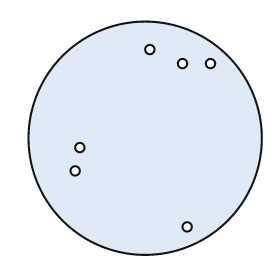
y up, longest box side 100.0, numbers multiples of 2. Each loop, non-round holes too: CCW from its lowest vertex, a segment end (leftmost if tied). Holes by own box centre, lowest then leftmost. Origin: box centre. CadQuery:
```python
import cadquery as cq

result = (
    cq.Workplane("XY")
    .moveTo(0.0, 0.0)
    .circle(50.0)
    .moveTo(18.0, -38.0)
    .circle(2.0)
    .moveTo(-30.0, -14.0)
    .circle(2.0)
    .moveTo(-28.0, -4.0)
    .circle(2.0)
    .moveTo(16.0, 32.0)
    .circle(2.0)
    .moveTo(28.0, 32.0)
    .circle(2.0)
    .moveTo(2.0, 38.0)
    .circle(2.0)
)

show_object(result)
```